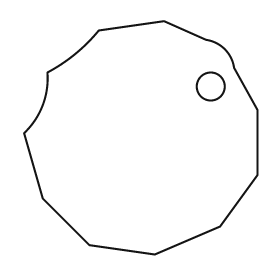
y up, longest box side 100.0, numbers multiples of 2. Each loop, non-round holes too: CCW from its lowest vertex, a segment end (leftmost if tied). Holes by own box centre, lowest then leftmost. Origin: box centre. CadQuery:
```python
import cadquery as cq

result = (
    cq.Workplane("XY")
    .moveTo(6.0, -50.0)
    .lineTo(34.0, -38.0)
    .lineTo(50.0, -16.0)
    .lineTo(50.0, 12.0)
    .lineTo(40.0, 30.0)
    .threePointArc((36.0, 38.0), (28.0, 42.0))
    .lineTo(10.0, 50.0)
    .lineTo(-18.0, 46.0)
    .threePointArc((-28.0, 36.0), (-40.0, 28.0))
    .threePointArc((-42.0, 14.0), (-50.0, 2.0))
    .lineTo(-42.0, -26.0)
    .lineTo(-22.0, -46.0)
    .close()
    .moveTo(30.0, 22.0)
    .circle(6.0)
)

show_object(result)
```